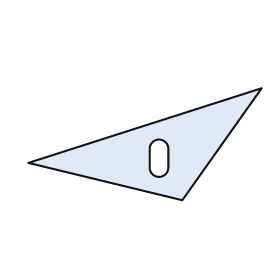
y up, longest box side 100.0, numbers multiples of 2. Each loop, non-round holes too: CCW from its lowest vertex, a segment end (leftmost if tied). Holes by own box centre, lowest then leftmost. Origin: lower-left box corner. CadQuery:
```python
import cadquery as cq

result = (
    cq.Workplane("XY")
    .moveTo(66.0, 0.0)
    .lineTo(100.0, 48.0)
    .lineTo(0.0, 16.0)
    .close()
    .moveTo(52.0, 14.0)
    .threePointArc((56.0, 10.0), (60.0, 14.0))
    .lineTo(60.0, 22.0)
    .threePointArc((56.0, 26.0), (52.0, 22.0))
    .close()
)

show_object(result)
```